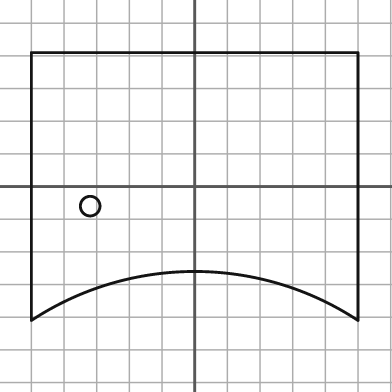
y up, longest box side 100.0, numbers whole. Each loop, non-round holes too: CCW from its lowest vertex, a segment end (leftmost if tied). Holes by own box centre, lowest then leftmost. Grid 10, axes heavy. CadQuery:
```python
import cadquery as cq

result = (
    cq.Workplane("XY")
    .moveTo(-50.0, -41.0)
    .threePointArc((0.0, -26.0), (50.0, -41.0))
    .lineTo(50.0, 41.0)
    .lineTo(-50.0, 41.0)
    .close()
    .moveTo(-32.0, -6.0)
    .circle(3.0)
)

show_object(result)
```